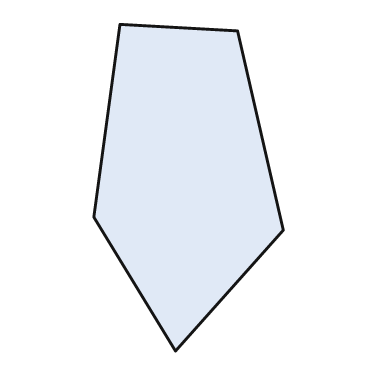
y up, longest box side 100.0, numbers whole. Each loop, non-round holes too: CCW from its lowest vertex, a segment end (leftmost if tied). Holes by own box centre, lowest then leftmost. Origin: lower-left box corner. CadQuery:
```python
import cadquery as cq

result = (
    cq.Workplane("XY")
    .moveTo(25.0, 0.0)
    .lineTo(58.0, 37.0)
    .lineTo(44.0, 98.0)
    .lineTo(8.0, 100.0)
    .lineTo(0.0, 41.0)
    .close()
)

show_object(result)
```